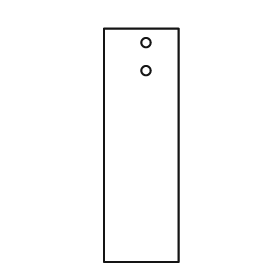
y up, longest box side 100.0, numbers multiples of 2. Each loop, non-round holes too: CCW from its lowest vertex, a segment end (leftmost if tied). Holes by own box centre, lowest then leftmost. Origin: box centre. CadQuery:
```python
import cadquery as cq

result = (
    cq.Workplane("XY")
    .moveTo(-16.0, -50.0)
    .lineTo(16.0, -50.0)
    .lineTo(16.0, 50.0)
    .lineTo(-16.0, 50.0)
    .close()
    .moveTo(2.0, 32.0)
    .circle(2.0)
    .moveTo(2.0, 44.0)
    .circle(2.0)
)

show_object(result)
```